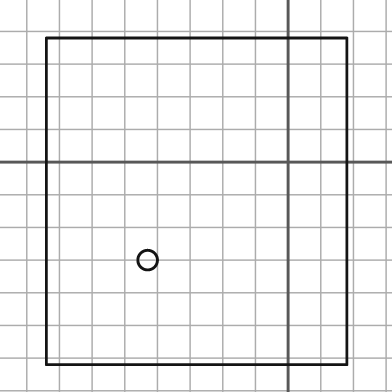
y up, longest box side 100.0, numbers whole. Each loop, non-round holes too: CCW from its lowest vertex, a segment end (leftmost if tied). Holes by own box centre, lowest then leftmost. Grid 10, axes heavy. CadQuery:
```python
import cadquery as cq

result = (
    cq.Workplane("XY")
    .moveTo(-74.0, -62.0)
    .lineTo(18.0, -62.0)
    .lineTo(18.0, 38.0)
    .lineTo(-74.0, 38.0)
    .close()
    .moveTo(-43.0, -30.0)
    .circle(3.0)
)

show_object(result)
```